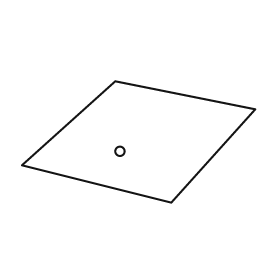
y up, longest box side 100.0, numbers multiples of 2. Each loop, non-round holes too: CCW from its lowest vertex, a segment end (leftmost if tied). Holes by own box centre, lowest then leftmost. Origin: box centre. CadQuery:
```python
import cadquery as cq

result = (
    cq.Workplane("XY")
    .moveTo(14.0, -26.0)
    .lineTo(50.0, 14.0)
    .lineTo(-10.0, 26.0)
    .lineTo(-50.0, -10.0)
    .close()
    .moveTo(-8.0, -4.0)
    .circle(2.0)
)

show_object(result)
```